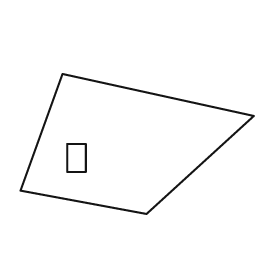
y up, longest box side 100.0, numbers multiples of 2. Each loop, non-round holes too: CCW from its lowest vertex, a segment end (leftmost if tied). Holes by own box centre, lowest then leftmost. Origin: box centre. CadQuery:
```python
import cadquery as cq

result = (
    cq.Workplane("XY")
    .moveTo(4.0, -30.0)
    .lineTo(50.0, 12.0)
    .lineTo(-32.0, 30.0)
    .lineTo(-50.0, -20.0)
    .close()
    .moveTo(-30.0, -12.0)
    .lineTo(-22.0, -12.0)
    .lineTo(-22.0, 0.0)
    .lineTo(-30.0, 0.0)
    .close()
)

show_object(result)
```